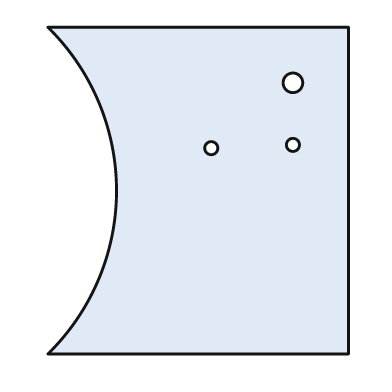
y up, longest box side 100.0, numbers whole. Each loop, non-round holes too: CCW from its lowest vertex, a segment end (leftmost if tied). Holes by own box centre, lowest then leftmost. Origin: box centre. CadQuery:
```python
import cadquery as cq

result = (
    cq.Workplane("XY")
    .moveTo(-46.0, -50.0)
    .lineTo(46.0, -50.0)
    .lineTo(46.0, 50.0)
    .lineTo(-46.0, 50.0)
    .threePointArc((-25.0, 0.0), (-46.0, -50.0))
    .close()
    .moveTo(4.0, 13.0)
    .circle(2.0)
    .moveTo(29.0, 14.0)
    .circle(2.0)
    .moveTo(29.0, 33.0)
    .circle(3.0)
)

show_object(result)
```